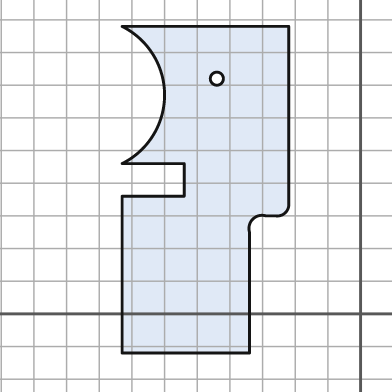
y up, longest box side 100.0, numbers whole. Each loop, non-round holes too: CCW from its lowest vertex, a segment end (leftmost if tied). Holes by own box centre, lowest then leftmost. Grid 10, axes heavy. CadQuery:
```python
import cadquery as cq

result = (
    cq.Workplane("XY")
    .moveTo(-73.0, -12.0)
    .lineTo(-34.0, -12.0)
    .lineTo(-34.0, 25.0)
    .threePointArc((-33.0, 29.0), (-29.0, 30.0))
    .lineTo(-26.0, 30.0)
    .threePointArc((-23.0, 31.0), (-22.0, 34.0))
    .lineTo(-22.0, 88.0)
    .lineTo(-73.0, 88.0)
    .threePointArc((-60.0, 67.0), (-73.0, 46.0))
    .lineTo(-54.0, 46.0)
    .lineTo(-54.0, 36.0)
    .lineTo(-73.0, 36.0)
    .close()
    .moveTo(-44.0, 72.0)
    .circle(2.0)
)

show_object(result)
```